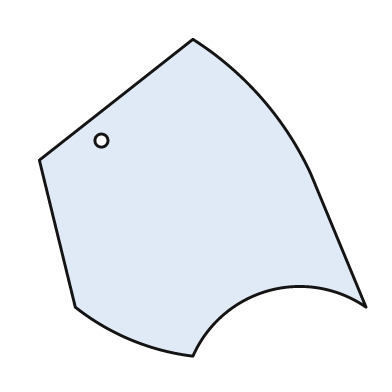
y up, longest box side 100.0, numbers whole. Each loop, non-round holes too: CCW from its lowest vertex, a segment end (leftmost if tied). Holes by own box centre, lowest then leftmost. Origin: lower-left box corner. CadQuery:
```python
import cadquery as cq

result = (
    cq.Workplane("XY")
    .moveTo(47.0, 0.0)
    .threePointArc((70.0, 20.0), (100.0, 15.0))
    .lineTo(83.0, 56.0)
    .threePointArc((68.0, 79.0), (47.0, 97.0))
    .lineTo(0.0, 60.0)
    .lineTo(11.0, 15.0)
    .threePointArc((28.0, 5.0), (47.0, 0.0))
    .close()
    .moveTo(19.0, 66.0)
    .circle(2.0)
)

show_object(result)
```